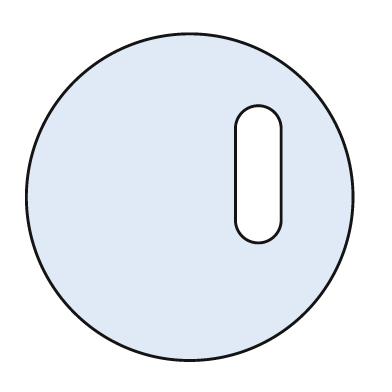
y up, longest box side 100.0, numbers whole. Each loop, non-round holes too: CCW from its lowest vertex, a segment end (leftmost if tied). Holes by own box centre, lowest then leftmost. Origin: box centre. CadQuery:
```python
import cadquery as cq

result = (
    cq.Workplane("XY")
    .moveTo(0.0, 0.0)
    .circle(50.0)
    .moveTo(14.0, -7.0)
    .threePointArc((21.0, -14.0), (28.0, -7.0))
    .lineTo(28.0, 21.0)
    .threePointArc((21.0, 28.0), (14.0, 21.0))
    .close()
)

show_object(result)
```